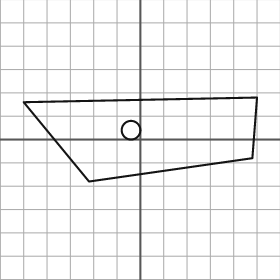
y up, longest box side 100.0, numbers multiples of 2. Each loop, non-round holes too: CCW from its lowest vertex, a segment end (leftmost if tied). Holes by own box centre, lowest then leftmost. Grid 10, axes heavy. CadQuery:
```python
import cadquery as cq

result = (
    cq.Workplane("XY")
    .moveTo(-22.0, -18.0)
    .lineTo(48.0, -8.0)
    .lineTo(50.0, 18.0)
    .lineTo(-50.0, 16.0)
    .close()
    .moveTo(-4.0, 4.0)
    .circle(4.0)
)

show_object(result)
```